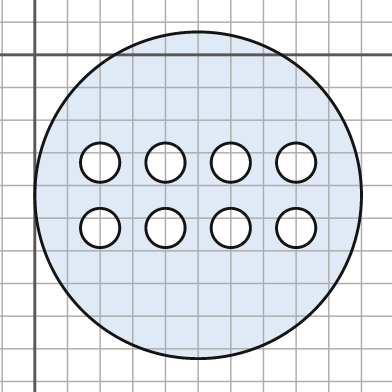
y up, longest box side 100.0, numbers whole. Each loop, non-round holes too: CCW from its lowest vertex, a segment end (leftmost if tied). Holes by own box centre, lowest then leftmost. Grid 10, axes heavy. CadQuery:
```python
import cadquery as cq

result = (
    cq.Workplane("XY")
    .moveTo(50.0, -43.0)
    .circle(50.0)
    .moveTo(20.0, -53.0)
    .circle(6.0)
    .moveTo(40.0, -53.0)
    .circle(6.0)
    .moveTo(60.0, -53.0)
    .circle(6.0)
    .moveTo(80.0, -53.0)
    .circle(6.0)
    .moveTo(20.0, -33.0)
    .circle(6.0)
    .moveTo(40.0, -33.0)
    .circle(6.0)
    .moveTo(60.0, -33.0)
    .circle(6.0)
    .moveTo(80.0, -33.0)
    .circle(6.0)
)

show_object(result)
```